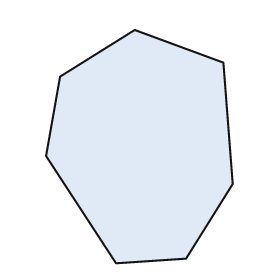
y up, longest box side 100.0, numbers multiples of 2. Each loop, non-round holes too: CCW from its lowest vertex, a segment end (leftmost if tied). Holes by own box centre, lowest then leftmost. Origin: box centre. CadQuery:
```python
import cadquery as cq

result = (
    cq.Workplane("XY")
    .moveTo(-10.0, -50.0)
    .lineTo(20.0, -48.0)
    .lineTo(40.0, -16.0)
    .lineTo(36.0, 36.0)
    .lineTo(-2.0, 50.0)
    .lineTo(-34.0, 30.0)
    .lineTo(-40.0, -4.0)
    .close()
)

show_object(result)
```